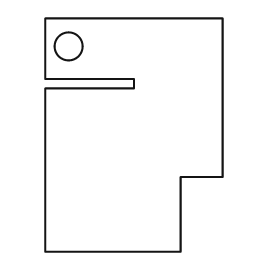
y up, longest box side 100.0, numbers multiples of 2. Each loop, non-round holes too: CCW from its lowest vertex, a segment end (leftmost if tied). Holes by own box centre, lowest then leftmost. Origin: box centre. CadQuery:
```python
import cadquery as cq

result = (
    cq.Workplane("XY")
    .moveTo(-38.0, -50.0)
    .lineTo(20.0, -50.0)
    .lineTo(20.0, -18.0)
    .lineTo(38.0, -18.0)
    .lineTo(38.0, 50.0)
    .lineTo(-38.0, 50.0)
    .lineTo(-38.0, 24.0)
    .lineTo(0.0, 24.0)
    .lineTo(0.0, 20.0)
    .lineTo(-38.0, 20.0)
    .close()
    .moveTo(-28.0, 38.0)
    .circle(6.0)
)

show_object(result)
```